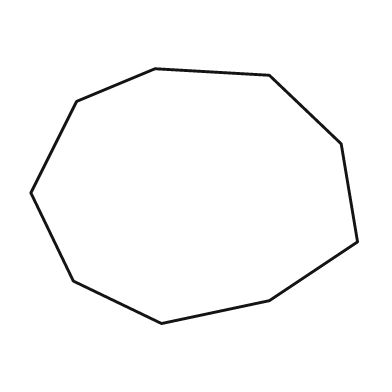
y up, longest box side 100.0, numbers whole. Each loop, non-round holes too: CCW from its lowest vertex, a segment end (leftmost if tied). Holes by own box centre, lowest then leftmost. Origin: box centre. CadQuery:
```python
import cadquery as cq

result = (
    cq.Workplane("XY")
    .moveTo(-10.0, -39.0)
    .lineTo(23.0, -32.0)
    .lineTo(50.0, -14.0)
    .lineTo(45.0, 16.0)
    .lineTo(23.0, 37.0)
    .lineTo(-12.0, 39.0)
    .lineTo(-36.0, 29.0)
    .lineTo(-50.0, 1.0)
    .lineTo(-37.0, -26.0)
    .close()
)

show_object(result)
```